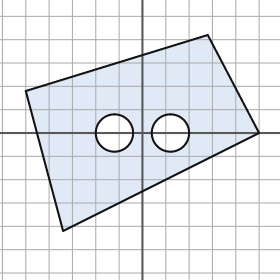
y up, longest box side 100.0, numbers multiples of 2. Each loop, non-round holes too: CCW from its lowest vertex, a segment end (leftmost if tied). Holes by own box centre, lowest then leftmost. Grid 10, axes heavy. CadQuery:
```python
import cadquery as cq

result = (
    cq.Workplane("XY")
    .moveTo(-34.0, -42.0)
    .lineTo(50.0, 0.0)
    .lineTo(28.0, 42.0)
    .lineTo(-50.0, 18.0)
    .close()
    .moveTo(-12.0, 0.0)
    .circle(8.0)
    .moveTo(12.0, 0.0)
    .circle(8.0)
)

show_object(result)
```